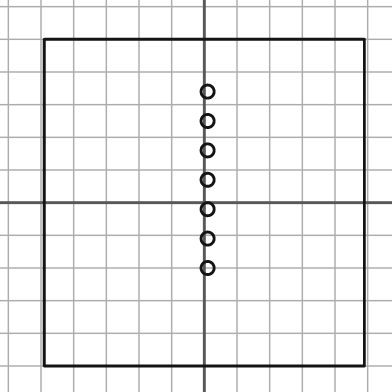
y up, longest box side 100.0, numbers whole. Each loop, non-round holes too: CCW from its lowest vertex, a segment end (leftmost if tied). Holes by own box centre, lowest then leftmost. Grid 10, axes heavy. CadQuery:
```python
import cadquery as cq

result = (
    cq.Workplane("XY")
    .moveTo(-49.0, -50.0)
    .lineTo(49.0, -50.0)
    .lineTo(49.0, 50.0)
    .lineTo(-49.0, 50.0)
    .close()
    .moveTo(1.0, -20.0)
    .circle(2.0)
    .moveTo(1.0, -11.0)
    .circle(2.0)
    .moveTo(1.0, -2.0)
    .circle(2.0)
    .moveTo(1.0, 7.0)
    .circle(2.0)
    .moveTo(1.0, 16.0)
    .circle(2.0)
    .moveTo(1.0, 25.0)
    .circle(2.0)
    .moveTo(1.0, 34.0)
    .circle(2.0)
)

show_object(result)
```